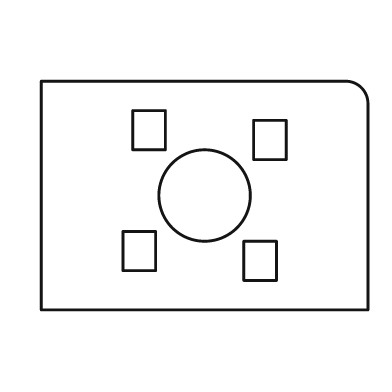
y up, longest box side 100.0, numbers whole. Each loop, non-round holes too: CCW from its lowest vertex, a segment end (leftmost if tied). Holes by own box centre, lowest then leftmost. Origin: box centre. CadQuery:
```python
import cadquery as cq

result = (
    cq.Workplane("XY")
    .moveTo(-50.0, -35.0)
    .lineTo(50.0, -35.0)
    .lineTo(50.0, 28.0)
    .threePointArc((48.0, 33.0), (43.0, 35.0))
    .lineTo(-50.0, 35.0)
    .close()
    .moveTo(12.0, -26.0)
    .lineTo(22.0, -26.0)
    .lineTo(22.0, -14.0)
    .lineTo(12.0, -14.0)
    .close()
    .moveTo(-25.0, -23.0)
    .lineTo(-15.0, -23.0)
    .lineTo(-15.0, -11.0)
    .lineTo(-25.0, -11.0)
    .close()
    .moveTo(0.0, 0.0)
    .circle(14.0)
    .moveTo(15.0, 11.0)
    .lineTo(25.0, 11.0)
    .lineTo(25.0, 23.0)
    .lineTo(15.0, 23.0)
    .close()
    .moveTo(-22.0, 14.0)
    .lineTo(-12.0, 14.0)
    .lineTo(-12.0, 26.0)
    .lineTo(-22.0, 26.0)
    .close()
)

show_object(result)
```